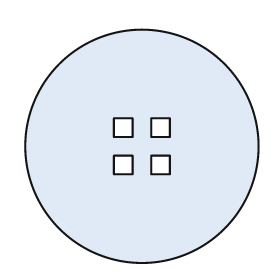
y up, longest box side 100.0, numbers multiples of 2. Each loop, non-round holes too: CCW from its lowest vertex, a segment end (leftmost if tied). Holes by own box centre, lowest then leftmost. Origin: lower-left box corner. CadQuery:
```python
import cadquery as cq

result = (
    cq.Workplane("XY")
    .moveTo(50.0, 50.0)
    .circle(50.0)
    .moveTo(38.0, 38.0)
    .lineTo(46.0, 38.0)
    .lineTo(46.0, 46.0)
    .lineTo(38.0, 46.0)
    .close()
    .moveTo(54.0, 38.0)
    .lineTo(62.0, 38.0)
    .lineTo(62.0, 46.0)
    .lineTo(54.0, 46.0)
    .close()
    .moveTo(38.0, 54.0)
    .lineTo(46.0, 54.0)
    .lineTo(46.0, 62.0)
    .lineTo(38.0, 62.0)
    .close()
    .moveTo(54.0, 54.0)
    .lineTo(62.0, 54.0)
    .lineTo(62.0, 62.0)
    .lineTo(54.0, 62.0)
    .close()
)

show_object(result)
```